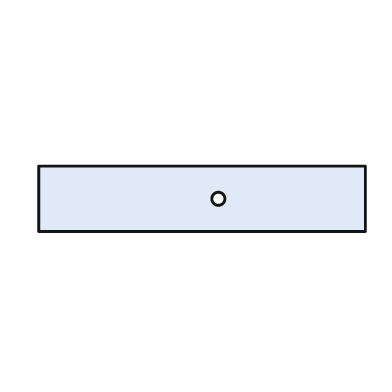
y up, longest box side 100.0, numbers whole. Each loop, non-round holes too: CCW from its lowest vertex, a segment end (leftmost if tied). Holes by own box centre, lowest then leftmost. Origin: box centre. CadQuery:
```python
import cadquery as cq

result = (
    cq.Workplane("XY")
    .moveTo(-50.0, -10.0)
    .lineTo(50.0, -10.0)
    .lineTo(50.0, 10.0)
    .lineTo(-50.0, 10.0)
    .close()
    .moveTo(5.0, 0.0)
    .circle(2.0)
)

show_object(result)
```